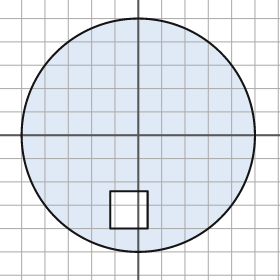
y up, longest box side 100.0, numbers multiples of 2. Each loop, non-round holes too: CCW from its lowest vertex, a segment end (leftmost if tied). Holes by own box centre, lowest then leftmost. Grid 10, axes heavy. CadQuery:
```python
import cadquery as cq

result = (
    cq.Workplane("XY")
    .moveTo(0.0, 0.0)
    .circle(50.0)
    .moveTo(-12.0, -40.0)
    .lineTo(4.0, -40.0)
    .lineTo(4.0, -24.0)
    .lineTo(-12.0, -24.0)
    .close()
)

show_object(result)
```